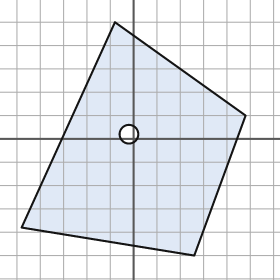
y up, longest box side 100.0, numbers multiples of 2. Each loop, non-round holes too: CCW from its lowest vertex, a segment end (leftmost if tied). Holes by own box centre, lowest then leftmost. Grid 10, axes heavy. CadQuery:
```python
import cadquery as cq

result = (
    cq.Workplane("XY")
    .moveTo(26.0, -50.0)
    .lineTo(48.0, 10.0)
    .lineTo(-8.0, 50.0)
    .lineTo(-48.0, -38.0)
    .close()
    .moveTo(-2.0, 2.0)
    .circle(4.0)
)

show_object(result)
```